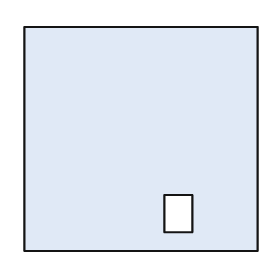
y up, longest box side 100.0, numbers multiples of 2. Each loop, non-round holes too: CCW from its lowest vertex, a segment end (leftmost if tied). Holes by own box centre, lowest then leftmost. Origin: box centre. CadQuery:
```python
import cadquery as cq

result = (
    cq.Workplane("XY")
    .moveTo(-50.0, -48.0)
    .lineTo(50.0, -48.0)
    .lineTo(50.0, 48.0)
    .lineTo(-50.0, 48.0)
    .close()
    .moveTo(10.0, -40.0)
    .lineTo(22.0, -40.0)
    .lineTo(22.0, -24.0)
    .lineTo(10.0, -24.0)
    .close()
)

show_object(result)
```